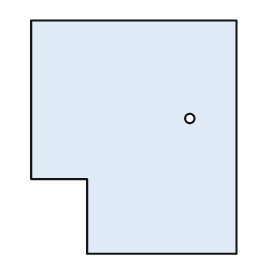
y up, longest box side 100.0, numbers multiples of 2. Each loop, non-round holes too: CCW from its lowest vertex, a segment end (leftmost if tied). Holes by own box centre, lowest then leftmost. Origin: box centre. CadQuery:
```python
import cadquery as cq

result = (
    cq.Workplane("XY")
    .moveTo(-20.0, -50.0)
    .lineTo(44.0, -50.0)
    .lineTo(44.0, 50.0)
    .lineTo(-44.0, 50.0)
    .lineTo(-44.0, -18.0)
    .lineTo(-20.0, -18.0)
    .close()
    .moveTo(24.0, 8.0)
    .circle(2.0)
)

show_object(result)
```